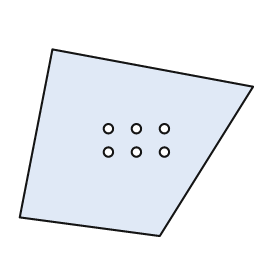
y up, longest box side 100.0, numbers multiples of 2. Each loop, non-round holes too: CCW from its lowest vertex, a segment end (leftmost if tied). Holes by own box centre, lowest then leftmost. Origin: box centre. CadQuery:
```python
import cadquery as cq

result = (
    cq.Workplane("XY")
    .moveTo(10.0, -40.0)
    .lineTo(50.0, 24.0)
    .lineTo(-36.0, 40.0)
    .lineTo(-50.0, -32.0)
    .close()
    .moveTo(-12.0, -4.0)
    .circle(2.0)
    .moveTo(0.0, -4.0)
    .circle(2.0)
    .moveTo(12.0, -4.0)
    .circle(2.0)
    .moveTo(-12.0, 6.0)
    .circle(2.0)
    .moveTo(0.0, 6.0)
    .circle(2.0)
    .moveTo(12.0, 6.0)
    .circle(2.0)
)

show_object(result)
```